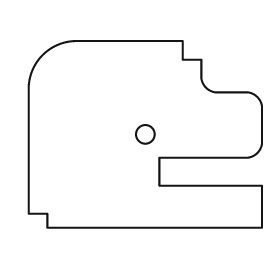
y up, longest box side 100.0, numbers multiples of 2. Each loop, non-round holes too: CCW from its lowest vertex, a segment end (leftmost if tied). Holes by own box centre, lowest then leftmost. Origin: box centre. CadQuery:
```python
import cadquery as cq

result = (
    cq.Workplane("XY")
    .moveTo(-42.0, -40.0)
    .lineTo(50.0, -40.0)
    .lineTo(50.0, -22.0)
    .lineTo(6.0, -22.0)
    .lineTo(6.0, -10.0)
    .lineTo(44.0, -10.0)
    .threePointArc((48.0, -8.0), (50.0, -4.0))
    .lineTo(50.0, 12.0)
    .threePointArc((48.0, 16.0), (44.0, 18.0))
    .lineTo(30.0, 18.0)
    .threePointArc((26.0, 20.0), (24.0, 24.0))
    .lineTo(24.0, 32.0)
    .lineTo(16.0, 32.0)
    .lineTo(16.0, 40.0)
    .lineTo(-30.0, 40.0)
    .threePointArc((-44.0, 34.0), (-50.0, 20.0))
    .lineTo(-50.0, -34.0)
    .lineTo(-42.0, -34.0)
    .close()
    .moveTo(0.0, 0.0)
    .circle(4.0)
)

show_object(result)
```